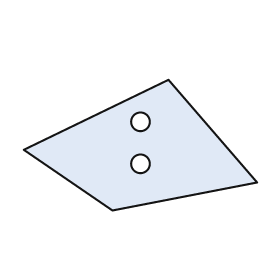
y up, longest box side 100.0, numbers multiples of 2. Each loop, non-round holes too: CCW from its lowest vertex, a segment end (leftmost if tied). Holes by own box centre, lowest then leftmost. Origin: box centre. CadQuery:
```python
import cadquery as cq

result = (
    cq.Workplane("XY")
    .moveTo(-12.0, -28.0)
    .lineTo(50.0, -16.0)
    .lineTo(12.0, 28.0)
    .lineTo(-50.0, -2.0)
    .close()
    .moveTo(0.0, -8.0)
    .circle(4.0)
    .moveTo(0.0, 10.0)
    .circle(4.0)
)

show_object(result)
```